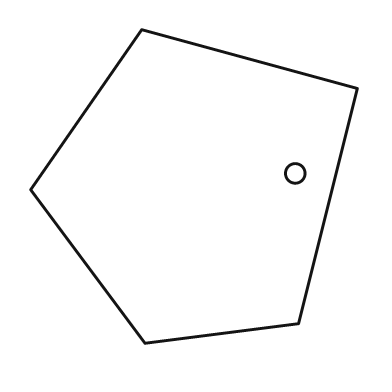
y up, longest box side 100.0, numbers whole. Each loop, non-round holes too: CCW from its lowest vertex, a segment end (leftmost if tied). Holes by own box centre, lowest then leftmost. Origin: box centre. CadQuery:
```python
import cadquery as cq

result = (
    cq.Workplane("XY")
    .moveTo(-15.0, -48.0)
    .lineTo(32.0, -42.0)
    .lineTo(50.0, 30.0)
    .lineTo(-16.0, 48.0)
    .lineTo(-50.0, -1.0)
    .close()
    .moveTo(31.0, 4.0)
    .circle(3.0)
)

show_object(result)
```